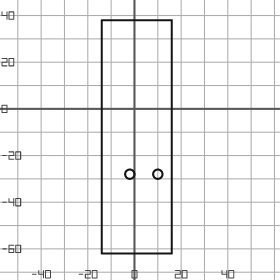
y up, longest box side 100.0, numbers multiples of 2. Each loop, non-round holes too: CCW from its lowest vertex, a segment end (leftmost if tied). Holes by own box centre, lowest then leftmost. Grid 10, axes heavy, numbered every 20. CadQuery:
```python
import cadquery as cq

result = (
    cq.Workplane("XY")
    .moveTo(-14.0, -62.0)
    .lineTo(16.0, -62.0)
    .lineTo(16.0, 38.0)
    .lineTo(-14.0, 38.0)
    .close()
    .moveTo(-2.0, -28.0)
    .circle(2.0)
    .moveTo(10.0, -28.0)
    .circle(2.0)
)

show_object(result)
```